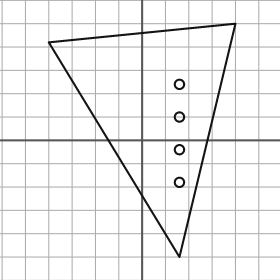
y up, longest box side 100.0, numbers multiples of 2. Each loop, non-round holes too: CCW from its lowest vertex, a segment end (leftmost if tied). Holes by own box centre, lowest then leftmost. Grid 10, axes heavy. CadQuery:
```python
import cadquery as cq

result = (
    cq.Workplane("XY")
    .moveTo(16.0, -50.0)
    .lineTo(40.0, 50.0)
    .lineTo(-40.0, 42.0)
    .close()
    .moveTo(16.0, -18.0)
    .circle(2.0)
    .moveTo(16.0, -4.0)
    .circle(2.0)
    .moveTo(16.0, 10.0)
    .circle(2.0)
    .moveTo(16.0, 24.0)
    .circle(2.0)
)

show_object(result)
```